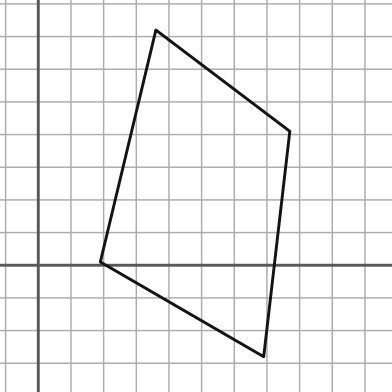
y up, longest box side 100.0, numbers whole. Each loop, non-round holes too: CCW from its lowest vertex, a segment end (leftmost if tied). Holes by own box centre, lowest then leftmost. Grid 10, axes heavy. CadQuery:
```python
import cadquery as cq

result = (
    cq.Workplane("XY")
    .moveTo(69.0, -28.0)
    .lineTo(77.0, 41.0)
    .lineTo(36.0, 72.0)
    .lineTo(19.0, 1.0)
    .close()
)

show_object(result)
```